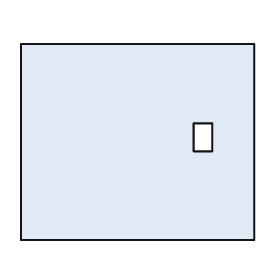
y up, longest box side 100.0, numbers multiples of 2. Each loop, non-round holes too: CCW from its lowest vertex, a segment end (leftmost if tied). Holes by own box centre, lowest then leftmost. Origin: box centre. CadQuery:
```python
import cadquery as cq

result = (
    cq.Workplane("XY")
    .moveTo(-50.0, -42.0)
    .lineTo(50.0, -42.0)
    .lineTo(50.0, 42.0)
    .lineTo(-50.0, 42.0)
    .close()
    .moveTo(24.0, -4.0)
    .lineTo(32.0, -4.0)
    .lineTo(32.0, 8.0)
    .lineTo(24.0, 8.0)
    .close()
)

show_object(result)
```